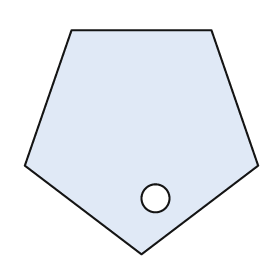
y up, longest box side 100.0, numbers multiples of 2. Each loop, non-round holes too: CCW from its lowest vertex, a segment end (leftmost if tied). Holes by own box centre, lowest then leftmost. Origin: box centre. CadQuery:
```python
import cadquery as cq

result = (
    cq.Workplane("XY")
    .moveTo(0.0, -48.0)
    .lineTo(50.0, -10.0)
    .lineTo(30.0, 48.0)
    .lineTo(-30.0, 48.0)
    .lineTo(-50.0, -10.0)
    .close()
    .moveTo(6.0, -24.0)
    .circle(6.0)
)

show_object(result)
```